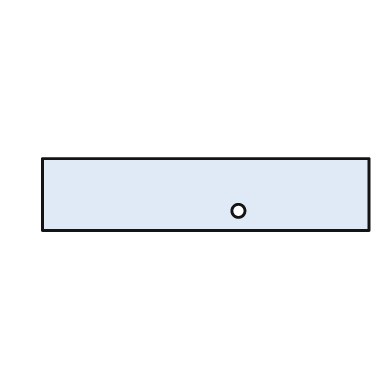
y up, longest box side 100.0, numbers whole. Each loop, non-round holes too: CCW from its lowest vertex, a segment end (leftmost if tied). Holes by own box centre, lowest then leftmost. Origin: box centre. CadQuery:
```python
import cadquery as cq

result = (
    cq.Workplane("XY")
    .moveTo(-50.0, -11.0)
    .lineTo(50.0, -11.0)
    .lineTo(50.0, 11.0)
    .lineTo(-50.0, 11.0)
    .close()
    .moveTo(10.0, -5.0)
    .circle(2.0)
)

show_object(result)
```